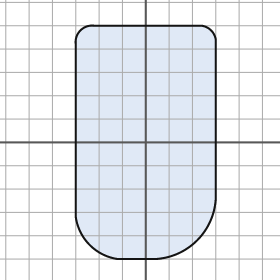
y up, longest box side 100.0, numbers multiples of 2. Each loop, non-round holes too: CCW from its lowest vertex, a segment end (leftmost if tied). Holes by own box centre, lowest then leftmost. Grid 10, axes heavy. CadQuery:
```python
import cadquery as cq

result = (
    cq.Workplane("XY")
    .moveTo(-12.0, -50.0)
    .lineTo(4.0, -50.0)
    .threePointArc((22.0, -42.0), (30.0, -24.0))
    .lineTo(30.0, 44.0)
    .threePointArc((28.0, 48.0), (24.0, 50.0))
    .lineTo(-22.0, 50.0)
    .threePointArc((-28.0, 48.0), (-30.0, 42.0))
    .lineTo(-30.0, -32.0)
    .threePointArc((-24.0, -44.0), (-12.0, -50.0))
    .close()
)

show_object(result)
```